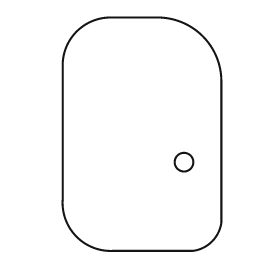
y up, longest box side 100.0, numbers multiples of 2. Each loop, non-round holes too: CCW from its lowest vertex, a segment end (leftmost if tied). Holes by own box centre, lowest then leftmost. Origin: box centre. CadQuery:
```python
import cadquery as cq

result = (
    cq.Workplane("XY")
    .moveTo(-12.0, -50.0)
    .lineTo(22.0, -50.0)
    .threePointArc((30.0, -46.0), (34.0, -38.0))
    .lineTo(34.0, 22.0)
    .threePointArc((26.0, 42.0), (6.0, 50.0))
    .lineTo(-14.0, 50.0)
    .threePointArc((-28.0, 44.0), (-34.0, 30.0))
    .lineTo(-34.0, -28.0)
    .threePointArc((-28.0, -44.0), (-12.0, -50.0))
    .close()
    .moveTo(18.0, -12.0)
    .circle(4.0)
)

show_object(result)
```